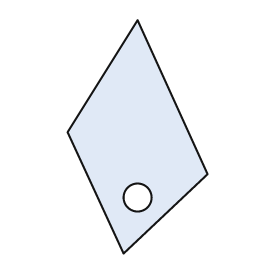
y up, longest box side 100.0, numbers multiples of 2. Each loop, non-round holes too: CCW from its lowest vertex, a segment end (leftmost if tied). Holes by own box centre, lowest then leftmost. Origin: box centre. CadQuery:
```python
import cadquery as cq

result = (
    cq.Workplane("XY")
    .moveTo(-6.0, -50.0)
    .lineTo(30.0, -16.0)
    .lineTo(0.0, 50.0)
    .lineTo(-30.0, 2.0)
    .close()
    .moveTo(0.0, -26.0)
    .circle(6.0)
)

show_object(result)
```